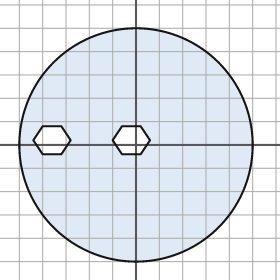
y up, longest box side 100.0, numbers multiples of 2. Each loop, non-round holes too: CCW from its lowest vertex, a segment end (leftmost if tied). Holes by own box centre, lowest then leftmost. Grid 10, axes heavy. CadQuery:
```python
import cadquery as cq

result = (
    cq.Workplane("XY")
    .moveTo(0.0, 0.0)
    .circle(50.0)
    .moveTo(-40.0, -4.0)
    .lineTo(-32.0, -4.0)
    .lineTo(-28.0, 2.0)
    .lineTo(-32.0, 8.0)
    .lineTo(-40.0, 8.0)
    .lineTo(-44.0, 2.0)
    .close()
    .moveTo(-6.0, -4.0)
    .lineTo(2.0, -4.0)
    .lineTo(6.0, 2.0)
    .lineTo(2.0, 8.0)
    .lineTo(-6.0, 8.0)
    .lineTo(-10.0, 2.0)
    .close()
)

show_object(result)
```